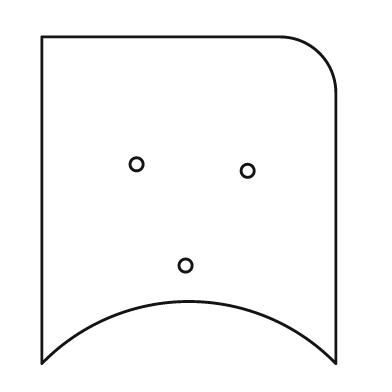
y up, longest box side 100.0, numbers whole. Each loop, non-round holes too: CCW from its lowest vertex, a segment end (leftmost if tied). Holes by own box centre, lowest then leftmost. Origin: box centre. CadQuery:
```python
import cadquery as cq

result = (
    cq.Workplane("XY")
    .moveTo(-45.0, -50.0)
    .threePointArc((0.0, -31.0), (45.0, -50.0))
    .lineTo(45.0, 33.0)
    .threePointArc((40.0, 45.0), (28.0, 50.0))
    .lineTo(-45.0, 50.0)
    .close()
    .moveTo(-1.0, -20.0)
    .circle(2.0)
    .moveTo(18.0, 9.0)
    .circle(2.0)
    .moveTo(-16.0, 11.0)
    .circle(2.0)
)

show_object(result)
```